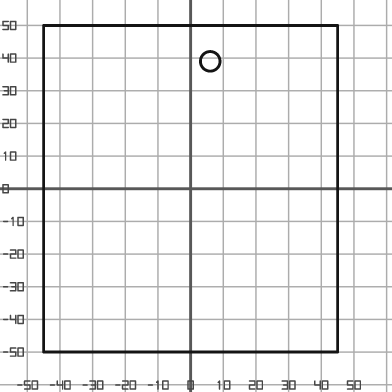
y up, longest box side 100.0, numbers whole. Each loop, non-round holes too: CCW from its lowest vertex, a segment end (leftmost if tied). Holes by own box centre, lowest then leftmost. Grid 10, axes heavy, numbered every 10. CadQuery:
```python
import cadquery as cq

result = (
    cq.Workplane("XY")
    .moveTo(-45.0, -50.0)
    .lineTo(45.0, -50.0)
    .lineTo(45.0, 50.0)
    .lineTo(-45.0, 50.0)
    .close()
    .moveTo(6.0, 39.0)
    .circle(3.0)
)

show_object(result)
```